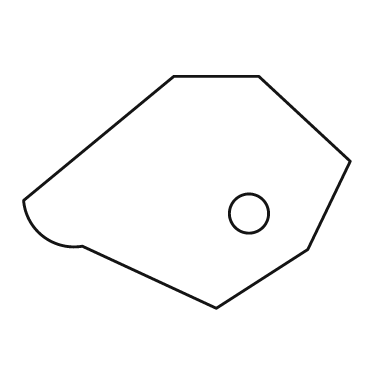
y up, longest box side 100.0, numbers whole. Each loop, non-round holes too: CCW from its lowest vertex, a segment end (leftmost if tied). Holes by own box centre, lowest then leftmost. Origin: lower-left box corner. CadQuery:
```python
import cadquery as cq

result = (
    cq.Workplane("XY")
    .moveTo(59.0, 0.0)
    .lineTo(87.0, 18.0)
    .lineTo(100.0, 45.0)
    .lineTo(72.0, 71.0)
    .lineTo(46.0, 71.0)
    .lineTo(0.0, 33.0)
    .threePointArc((6.0, 22.0), (18.0, 19.0))
    .close()
    .moveTo(69.0, 29.0)
    .circle(6.0)
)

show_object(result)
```